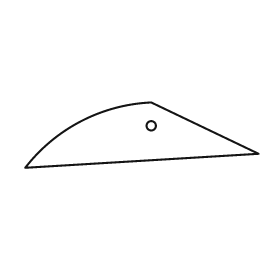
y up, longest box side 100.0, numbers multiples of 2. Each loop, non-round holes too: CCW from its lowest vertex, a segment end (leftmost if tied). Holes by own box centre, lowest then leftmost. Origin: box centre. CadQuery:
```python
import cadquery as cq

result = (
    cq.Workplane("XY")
    .moveTo(-50.0, -14.0)
    .lineTo(50.0, -8.0)
    .lineTo(4.0, 14.0)
    .threePointArc((-26.0, 6.0), (-50.0, -14.0))
    .close()
    .moveTo(4.0, 4.0)
    .circle(2.0)
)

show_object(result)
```